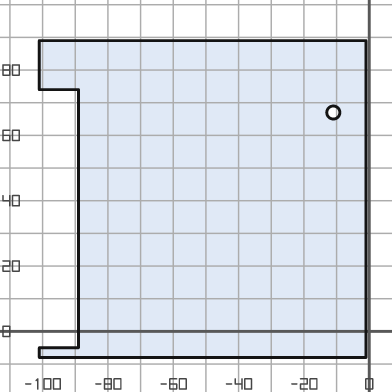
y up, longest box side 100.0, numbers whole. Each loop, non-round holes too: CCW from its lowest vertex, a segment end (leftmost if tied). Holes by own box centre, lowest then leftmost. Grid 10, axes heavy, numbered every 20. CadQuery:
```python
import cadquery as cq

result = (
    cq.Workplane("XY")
    .moveTo(-101.0, -8.0)
    .lineTo(-1.0, -8.0)
    .lineTo(-1.0, 89.0)
    .lineTo(-101.0, 89.0)
    .lineTo(-101.0, 74.0)
    .lineTo(-89.0, 74.0)
    .lineTo(-89.0, -5.0)
    .lineTo(-101.0, -5.0)
    .close()
    .moveTo(-11.0, 67.0)
    .circle(2.0)
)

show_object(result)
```